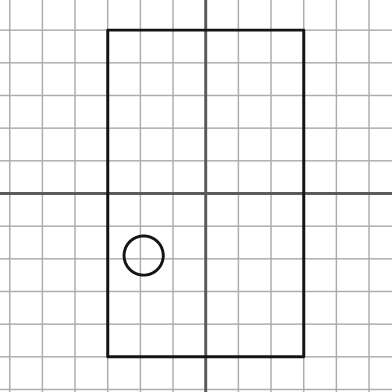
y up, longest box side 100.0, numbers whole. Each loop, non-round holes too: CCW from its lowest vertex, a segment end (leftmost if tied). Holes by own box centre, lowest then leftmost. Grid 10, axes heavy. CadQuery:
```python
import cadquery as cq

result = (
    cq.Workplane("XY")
    .moveTo(-30.0, -50.0)
    .lineTo(30.0, -50.0)
    .lineTo(30.0, 50.0)
    .lineTo(-30.0, 50.0)
    .close()
    .moveTo(-19.0, -19.0)
    .circle(6.0)
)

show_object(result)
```